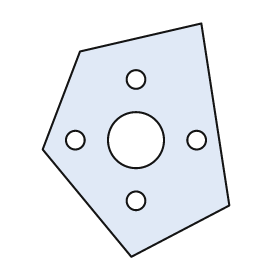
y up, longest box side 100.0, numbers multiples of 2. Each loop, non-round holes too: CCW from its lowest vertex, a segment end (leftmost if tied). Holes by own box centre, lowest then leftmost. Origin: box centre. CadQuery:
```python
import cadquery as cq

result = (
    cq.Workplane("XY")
    .moveTo(-2.0, -50.0)
    .lineTo(40.0, -28.0)
    .lineTo(28.0, 50.0)
    .lineTo(-24.0, 38.0)
    .lineTo(-40.0, -4.0)
    .close()
    .moveTo(0.0, -26.0)
    .circle(4.0)
    .moveTo(-26.0, 0.0)
    .circle(4.0)
    .moveTo(0.0, 0.0)
    .circle(12.0)
    .moveTo(26.0, 0.0)
    .circle(4.0)
    .moveTo(0.0, 26.0)
    .circle(4.0)
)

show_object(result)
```